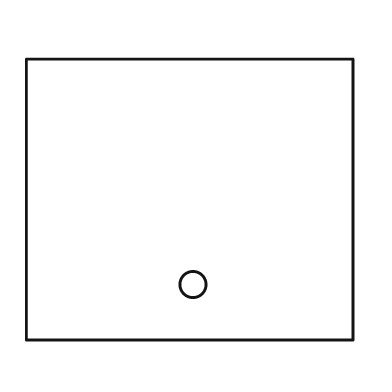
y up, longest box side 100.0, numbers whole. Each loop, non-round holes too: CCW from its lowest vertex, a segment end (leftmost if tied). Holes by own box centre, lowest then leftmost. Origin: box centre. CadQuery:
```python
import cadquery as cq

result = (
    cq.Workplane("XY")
    .moveTo(-50.0, -43.0)
    .lineTo(50.0, -43.0)
    .lineTo(50.0, 43.0)
    .lineTo(-50.0, 43.0)
    .close()
    .moveTo(1.0, -26.0)
    .circle(4.0)
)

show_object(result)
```